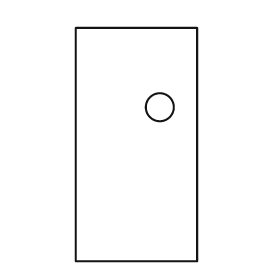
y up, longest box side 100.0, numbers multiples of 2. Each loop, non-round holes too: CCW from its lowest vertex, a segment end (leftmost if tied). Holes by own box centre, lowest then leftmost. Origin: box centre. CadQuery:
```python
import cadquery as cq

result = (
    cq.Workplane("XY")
    .moveTo(-26.0, -50.0)
    .lineTo(26.0, -50.0)
    .lineTo(26.0, 50.0)
    .lineTo(-26.0, 50.0)
    .close()
    .moveTo(10.0, 16.0)
    .circle(6.0)
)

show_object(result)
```